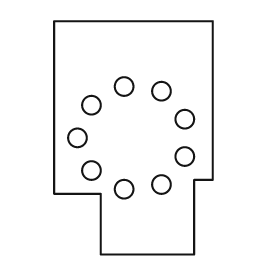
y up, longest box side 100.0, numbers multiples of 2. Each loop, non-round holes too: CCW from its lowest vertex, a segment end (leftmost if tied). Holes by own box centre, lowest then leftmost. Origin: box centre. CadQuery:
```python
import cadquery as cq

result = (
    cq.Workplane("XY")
    .moveTo(-14.0, -50.0)
    .lineTo(26.0, -50.0)
    .lineTo(26.0, -18.0)
    .lineTo(34.0, -18.0)
    .lineTo(34.0, 50.0)
    .lineTo(-34.0, 50.0)
    .lineTo(-34.0, -24.0)
    .lineTo(-14.0, -24.0)
    .close()
    .moveTo(-4.0, -22.0)
    .circle(4.0)
    .moveTo(12.0, -20.0)
    .circle(4.0)
    .moveTo(-18.0, -14.0)
    .circle(4.0)
    .moveTo(22.0, -8.0)
    .circle(4.0)
    .moveTo(-24.0, 0.0)
    .circle(4.0)
    .moveTo(22.0, 8.0)
    .circle(4.0)
    .moveTo(-18.0, 14.0)
    .circle(4.0)
    .moveTo(12.0, 20.0)
    .circle(4.0)
    .moveTo(-4.0, 22.0)
    .circle(4.0)
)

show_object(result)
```